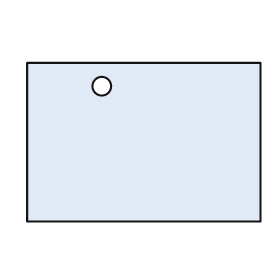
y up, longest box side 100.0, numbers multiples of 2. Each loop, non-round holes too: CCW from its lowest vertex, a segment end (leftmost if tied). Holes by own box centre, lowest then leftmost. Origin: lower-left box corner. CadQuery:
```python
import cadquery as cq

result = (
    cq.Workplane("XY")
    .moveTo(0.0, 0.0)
    .lineTo(100.0, 0.0)
    .lineTo(100.0, 68.0)
    .lineTo(0.0, 68.0)
    .close()
    .moveTo(32.0, 58.0)
    .circle(4.0)
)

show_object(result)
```